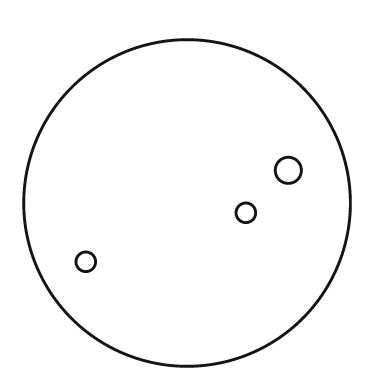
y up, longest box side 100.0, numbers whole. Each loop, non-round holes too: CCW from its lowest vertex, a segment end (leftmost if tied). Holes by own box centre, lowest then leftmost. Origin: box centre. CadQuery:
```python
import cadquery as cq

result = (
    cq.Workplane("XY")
    .moveTo(0.0, 0.0)
    .circle(50.0)
    .moveTo(-31.0, -18.0)
    .circle(3.0)
    .moveTo(18.0, -3.0)
    .circle(3.0)
    .moveTo(31.0, 10.0)
    .circle(4.0)
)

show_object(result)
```